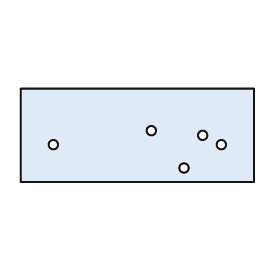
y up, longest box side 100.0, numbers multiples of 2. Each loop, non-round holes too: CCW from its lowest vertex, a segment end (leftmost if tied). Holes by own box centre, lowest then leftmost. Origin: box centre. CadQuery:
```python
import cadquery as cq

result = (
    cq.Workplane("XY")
    .moveTo(-50.0, -20.0)
    .lineTo(50.0, -20.0)
    .lineTo(50.0, 20.0)
    .lineTo(-50.0, 20.0)
    .close()
    .moveTo(20.0, -14.0)
    .circle(2.0)
    .moveTo(-36.0, -4.0)
    .circle(2.0)
    .moveTo(36.0, -4.0)
    .circle(2.0)
    .moveTo(28.0, 0.0)
    .circle(2.0)
    .moveTo(6.0, 2.0)
    .circle(2.0)
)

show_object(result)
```